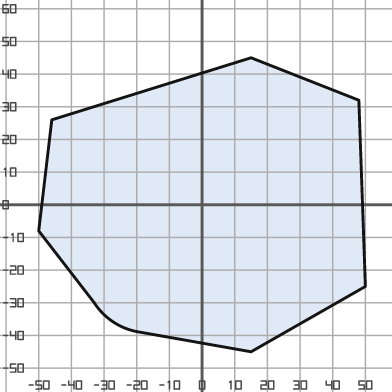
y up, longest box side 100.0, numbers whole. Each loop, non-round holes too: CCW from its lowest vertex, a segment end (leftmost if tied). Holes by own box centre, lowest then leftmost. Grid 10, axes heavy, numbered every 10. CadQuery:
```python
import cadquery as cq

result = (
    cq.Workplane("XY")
    .moveTo(15.0, -45.0)
    .lineTo(50.0, -25.0)
    .lineTo(48.0, 32.0)
    .lineTo(15.0, 45.0)
    .lineTo(-46.0, 26.0)
    .lineTo(-50.0, -8.0)
    .lineTo(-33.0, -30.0)
    .threePointArc((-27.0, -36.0), (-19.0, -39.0))
    .close()
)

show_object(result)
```